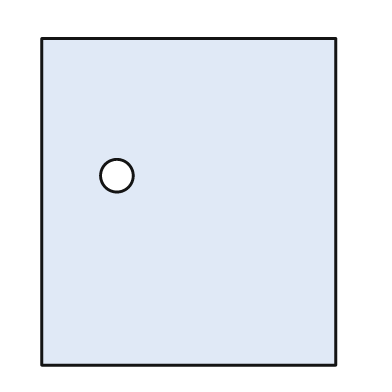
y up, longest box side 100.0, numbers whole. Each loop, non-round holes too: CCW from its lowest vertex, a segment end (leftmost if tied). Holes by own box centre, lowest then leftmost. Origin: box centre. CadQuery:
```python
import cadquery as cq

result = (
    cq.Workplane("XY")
    .moveTo(-45.0, -50.0)
    .lineTo(45.0, -50.0)
    .lineTo(45.0, 50.0)
    .lineTo(-45.0, 50.0)
    .close()
    .moveTo(-22.0, 8.0)
    .circle(5.0)
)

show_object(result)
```